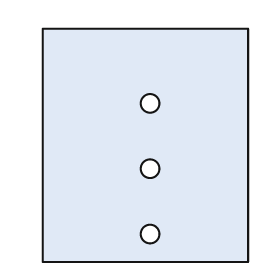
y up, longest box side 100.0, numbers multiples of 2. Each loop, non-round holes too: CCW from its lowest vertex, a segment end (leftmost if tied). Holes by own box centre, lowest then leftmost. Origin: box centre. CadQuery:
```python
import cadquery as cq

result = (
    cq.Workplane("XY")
    .moveTo(-44.0, -50.0)
    .lineTo(44.0, -50.0)
    .lineTo(44.0, 50.0)
    .lineTo(-44.0, 50.0)
    .close()
    .moveTo(2.0, -38.0)
    .circle(4.0)
    .moveTo(2.0, -10.0)
    .circle(4.0)
    .moveTo(2.0, 18.0)
    .circle(4.0)
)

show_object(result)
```